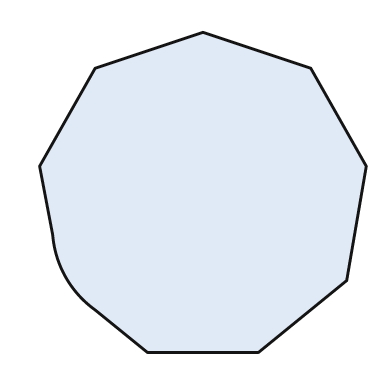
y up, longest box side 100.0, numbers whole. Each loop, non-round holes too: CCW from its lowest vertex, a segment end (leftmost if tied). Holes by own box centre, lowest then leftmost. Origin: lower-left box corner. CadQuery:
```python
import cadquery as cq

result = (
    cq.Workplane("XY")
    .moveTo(33.0, 0.0)
    .lineTo(67.0, 0.0)
    .lineTo(94.0, 22.0)
    .lineTo(100.0, 57.0)
    .lineTo(83.0, 87.0)
    .lineTo(50.0, 98.0)
    .lineTo(17.0, 87.0)
    .lineTo(0.0, 57.0)
    .lineTo(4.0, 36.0)
    .threePointArc((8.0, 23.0), (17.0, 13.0))
    .close()
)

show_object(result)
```